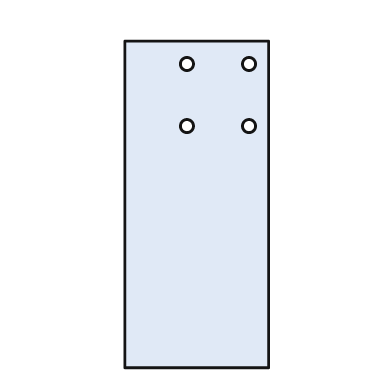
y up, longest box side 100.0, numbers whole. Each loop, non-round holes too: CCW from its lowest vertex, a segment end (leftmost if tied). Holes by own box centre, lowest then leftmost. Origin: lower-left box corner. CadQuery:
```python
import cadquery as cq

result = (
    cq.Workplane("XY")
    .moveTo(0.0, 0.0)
    .lineTo(44.0, 0.0)
    .lineTo(44.0, 100.0)
    .lineTo(0.0, 100.0)
    .close()
    .moveTo(19.0, 74.0)
    .circle(2.0)
    .moveTo(38.0, 74.0)
    .circle(2.0)
    .moveTo(19.0, 93.0)
    .circle(2.0)
    .moveTo(38.0, 93.0)
    .circle(2.0)
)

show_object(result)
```